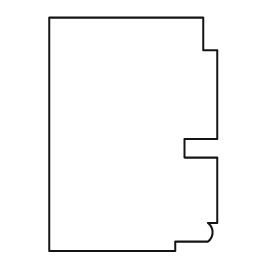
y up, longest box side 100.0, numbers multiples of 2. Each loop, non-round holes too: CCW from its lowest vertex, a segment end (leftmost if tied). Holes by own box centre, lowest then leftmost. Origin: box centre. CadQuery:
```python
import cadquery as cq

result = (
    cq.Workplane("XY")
    .moveTo(-36.0, -50.0)
    .lineTo(18.0, -50.0)
    .lineTo(18.0, -46.0)
    .lineTo(32.0, -46.0)
    .threePointArc((34.0, -42.0), (32.0, -38.0))
    .lineTo(36.0, -38.0)
    .lineTo(36.0, -10.0)
    .lineTo(22.0, -10.0)
    .lineTo(22.0, -2.0)
    .lineTo(36.0, -2.0)
    .lineTo(36.0, 36.0)
    .lineTo(30.0, 36.0)
    .lineTo(30.0, 50.0)
    .lineTo(-36.0, 50.0)
    .close()
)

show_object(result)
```